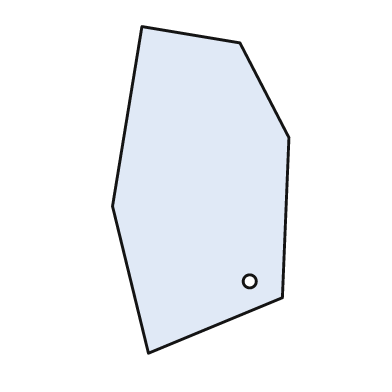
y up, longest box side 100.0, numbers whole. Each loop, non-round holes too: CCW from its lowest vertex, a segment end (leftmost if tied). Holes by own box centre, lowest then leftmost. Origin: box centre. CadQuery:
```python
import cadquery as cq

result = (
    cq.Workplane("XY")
    .moveTo(-16.0, -50.0)
    .lineTo(25.0, -33.0)
    .lineTo(27.0, 16.0)
    .lineTo(12.0, 45.0)
    .lineTo(-18.0, 50.0)
    .lineTo(-27.0, -5.0)
    .close()
    .moveTo(15.0, -28.0)
    .circle(2.0)
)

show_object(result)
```